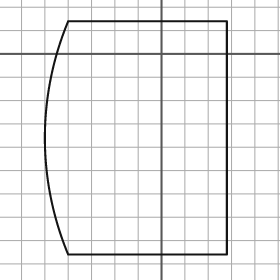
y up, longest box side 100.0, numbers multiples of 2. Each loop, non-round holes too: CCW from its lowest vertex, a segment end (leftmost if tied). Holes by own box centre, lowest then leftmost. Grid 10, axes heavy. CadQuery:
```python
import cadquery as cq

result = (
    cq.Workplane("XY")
    .moveTo(-40.0, -86.0)
    .lineTo(28.0, -86.0)
    .lineTo(28.0, 14.0)
    .lineTo(-40.0, 14.0)
    .threePointArc((-50.0, -36.0), (-40.0, -86.0))
    .close()
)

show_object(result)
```